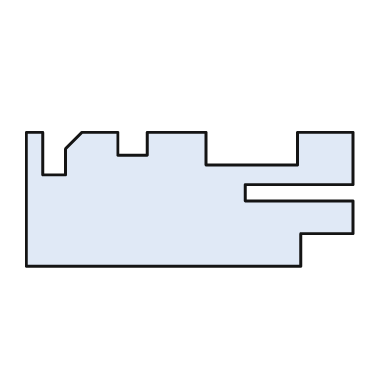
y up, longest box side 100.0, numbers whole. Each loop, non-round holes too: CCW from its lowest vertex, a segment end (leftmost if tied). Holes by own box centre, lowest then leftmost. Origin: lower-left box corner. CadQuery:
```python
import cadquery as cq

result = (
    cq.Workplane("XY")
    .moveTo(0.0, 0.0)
    .lineTo(84.0, 0.0)
    .lineTo(84.0, 10.0)
    .lineTo(100.0, 10.0)
    .lineTo(100.0, 20.0)
    .lineTo(67.0, 20.0)
    .lineTo(67.0, 25.0)
    .lineTo(100.0, 25.0)
    .lineTo(100.0, 41.0)
    .lineTo(83.0, 41.0)
    .lineTo(83.0, 31.0)
    .lineTo(55.0, 31.0)
    .lineTo(55.0, 41.0)
    .lineTo(37.0, 41.0)
    .lineTo(37.0, 34.0)
    .lineTo(28.0, 34.0)
    .lineTo(28.0, 41.0)
    .lineTo(17.0, 41.0)
    .lineTo(12.0, 36.0)
    .lineTo(12.0, 28.0)
    .lineTo(5.0, 28.0)
    .lineTo(5.0, 41.0)
    .lineTo(0.0, 41.0)
    .close()
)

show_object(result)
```